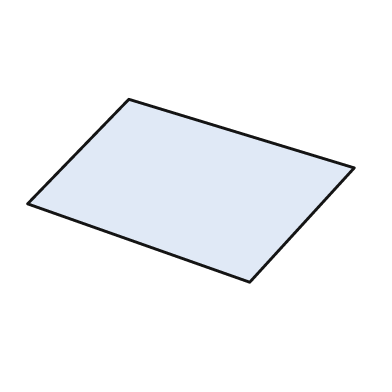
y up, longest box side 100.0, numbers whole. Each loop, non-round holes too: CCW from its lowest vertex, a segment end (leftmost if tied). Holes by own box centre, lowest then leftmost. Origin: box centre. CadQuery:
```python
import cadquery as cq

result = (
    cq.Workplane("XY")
    .moveTo(18.0, -28.0)
    .lineTo(50.0, 7.0)
    .lineTo(-19.0, 28.0)
    .lineTo(-50.0, -4.0)
    .close()
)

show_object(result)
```